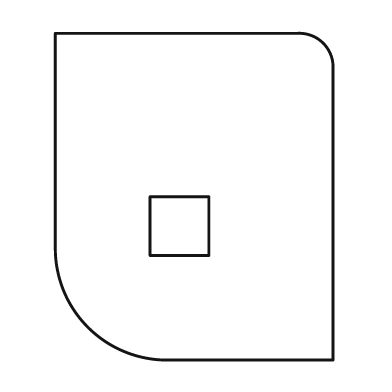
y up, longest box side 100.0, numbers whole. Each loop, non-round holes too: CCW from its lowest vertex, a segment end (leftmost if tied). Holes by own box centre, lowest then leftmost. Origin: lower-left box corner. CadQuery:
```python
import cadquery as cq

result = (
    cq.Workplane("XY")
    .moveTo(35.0, 0.0)
    .lineTo(85.0, 0.0)
    .lineTo(85.0, 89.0)
    .threePointArc((82.0, 97.0), (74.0, 100.0))
    .lineTo(0.0, 100.0)
    .lineTo(0.0, 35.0)
    .threePointArc((10.0, 10.0), (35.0, 0.0))
    .close()
    .moveTo(29.0, 32.0)
    .lineTo(47.0, 32.0)
    .lineTo(47.0, 50.0)
    .lineTo(29.0, 50.0)
    .close()
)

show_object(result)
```